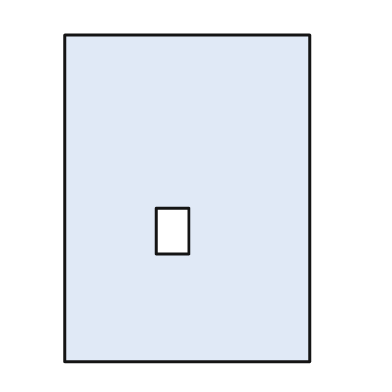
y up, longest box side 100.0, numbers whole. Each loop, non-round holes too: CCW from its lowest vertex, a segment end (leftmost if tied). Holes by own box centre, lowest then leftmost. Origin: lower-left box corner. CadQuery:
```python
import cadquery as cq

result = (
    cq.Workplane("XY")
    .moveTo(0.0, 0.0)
    .lineTo(75.0, 0.0)
    .lineTo(75.0, 100.0)
    .lineTo(0.0, 100.0)
    .close()
    .moveTo(28.0, 33.0)
    .lineTo(38.0, 33.0)
    .lineTo(38.0, 47.0)
    .lineTo(28.0, 47.0)
    .close()
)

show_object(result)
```